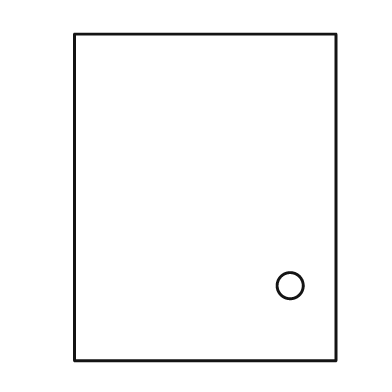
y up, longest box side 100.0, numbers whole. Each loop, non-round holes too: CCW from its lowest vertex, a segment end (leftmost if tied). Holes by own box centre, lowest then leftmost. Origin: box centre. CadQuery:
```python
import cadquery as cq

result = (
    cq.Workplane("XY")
    .moveTo(-40.0, -50.0)
    .lineTo(40.0, -50.0)
    .lineTo(40.0, 50.0)
    .lineTo(-40.0, 50.0)
    .close()
    .moveTo(26.0, -27.0)
    .circle(4.0)
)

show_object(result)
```